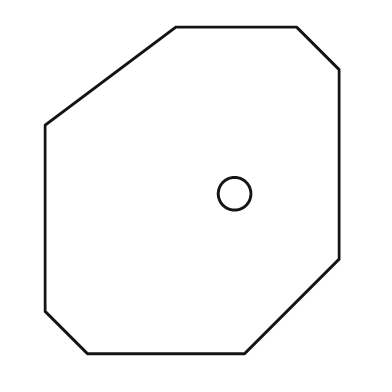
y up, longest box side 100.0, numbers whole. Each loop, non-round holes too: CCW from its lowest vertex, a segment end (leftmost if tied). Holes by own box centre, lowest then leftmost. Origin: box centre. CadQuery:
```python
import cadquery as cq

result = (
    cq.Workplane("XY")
    .moveTo(-32.0, -50.0)
    .lineTo(16.0, -50.0)
    .lineTo(45.0, -21.0)
    .lineTo(45.0, 37.0)
    .lineTo(32.0, 50.0)
    .lineTo(-5.0, 50.0)
    .lineTo(-45.0, 20.0)
    .lineTo(-45.0, -37.0)
    .close()
    .moveTo(13.0, -1.0)
    .circle(5.0)
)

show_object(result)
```